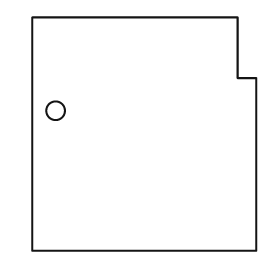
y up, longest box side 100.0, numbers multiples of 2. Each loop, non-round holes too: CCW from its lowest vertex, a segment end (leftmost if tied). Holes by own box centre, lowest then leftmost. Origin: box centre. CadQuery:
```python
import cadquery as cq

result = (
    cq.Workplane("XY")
    .moveTo(-48.0, -50.0)
    .lineTo(48.0, -50.0)
    .lineTo(48.0, 24.0)
    .lineTo(40.0, 24.0)
    .lineTo(40.0, 50.0)
    .lineTo(-48.0, 50.0)
    .close()
    .moveTo(-38.0, 10.0)
    .circle(4.0)
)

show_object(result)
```